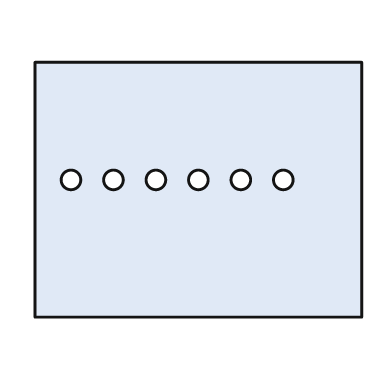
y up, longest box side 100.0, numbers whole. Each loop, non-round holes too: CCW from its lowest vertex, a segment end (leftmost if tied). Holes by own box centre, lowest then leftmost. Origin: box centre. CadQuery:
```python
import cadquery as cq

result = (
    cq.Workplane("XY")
    .moveTo(-50.0, -39.0)
    .lineTo(50.0, -39.0)
    .lineTo(50.0, 39.0)
    .lineTo(-50.0, 39.0)
    .close()
    .moveTo(-39.0, 3.0)
    .circle(3.0)
    .moveTo(-26.0, 3.0)
    .circle(3.0)
    .moveTo(-13.0, 3.0)
    .circle(3.0)
    .moveTo(0.0, 3.0)
    .circle(3.0)
    .moveTo(13.0, 3.0)
    .circle(3.0)
    .moveTo(26.0, 3.0)
    .circle(3.0)
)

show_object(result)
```